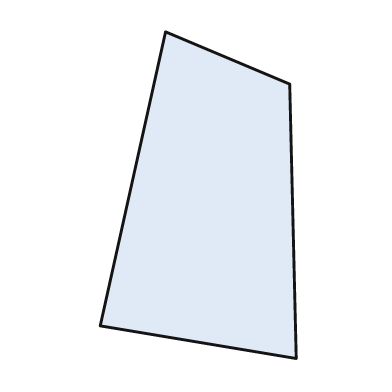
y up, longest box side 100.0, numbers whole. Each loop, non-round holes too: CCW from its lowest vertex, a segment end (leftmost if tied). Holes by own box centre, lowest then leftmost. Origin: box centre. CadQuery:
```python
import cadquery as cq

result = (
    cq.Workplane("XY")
    .moveTo(30.0, -50.0)
    .lineTo(28.0, 34.0)
    .lineTo(-10.0, 50.0)
    .lineTo(-30.0, -40.0)
    .close()
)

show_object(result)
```